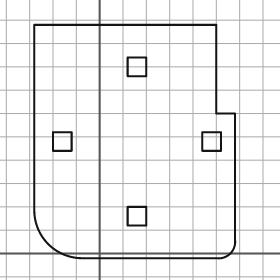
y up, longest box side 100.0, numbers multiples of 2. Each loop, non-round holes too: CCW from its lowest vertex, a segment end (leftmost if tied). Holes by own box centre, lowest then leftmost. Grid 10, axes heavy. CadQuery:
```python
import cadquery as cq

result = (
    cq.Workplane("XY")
    .moveTo(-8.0, -2.0)
    .lineTo(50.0, -2.0)
    .threePointArc((56.0, 0.0), (58.0, 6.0))
    .lineTo(58.0, 60.0)
    .lineTo(50.0, 60.0)
    .lineTo(50.0, 98.0)
    .lineTo(-28.0, 98.0)
    .lineTo(-28.0, 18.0)
    .threePointArc((-22.0, 4.0), (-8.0, -2.0))
    .close()
    .moveTo(12.0, 12.0)
    .lineTo(20.0, 12.0)
    .lineTo(20.0, 20.0)
    .lineTo(12.0, 20.0)
    .close()
    .moveTo(-20.0, 44.0)
    .lineTo(-12.0, 44.0)
    .lineTo(-12.0, 52.0)
    .lineTo(-20.0, 52.0)
    .close()
    .moveTo(44.0, 44.0)
    .lineTo(52.0, 44.0)
    .lineTo(52.0, 52.0)
    .lineTo(44.0, 52.0)
    .close()
    .moveTo(12.0, 76.0)
    .lineTo(20.0, 76.0)
    .lineTo(20.0, 84.0)
    .lineTo(12.0, 84.0)
    .close()
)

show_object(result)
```